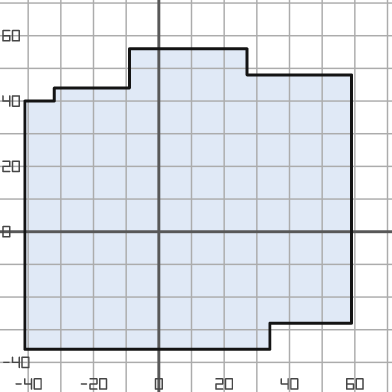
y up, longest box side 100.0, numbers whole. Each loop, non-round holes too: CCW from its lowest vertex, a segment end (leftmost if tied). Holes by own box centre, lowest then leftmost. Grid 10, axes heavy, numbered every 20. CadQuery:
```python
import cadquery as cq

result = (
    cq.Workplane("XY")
    .moveTo(-41.0, -36.0)
    .lineTo(34.0, -36.0)
    .lineTo(34.0, -28.0)
    .lineTo(59.0, -28.0)
    .lineTo(59.0, 48.0)
    .lineTo(27.0, 48.0)
    .lineTo(27.0, 56.0)
    .lineTo(-9.0, 56.0)
    .lineTo(-9.0, 44.0)
    .lineTo(-32.0, 44.0)
    .lineTo(-32.0, 40.0)
    .lineTo(-41.0, 40.0)
    .close()
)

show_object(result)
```